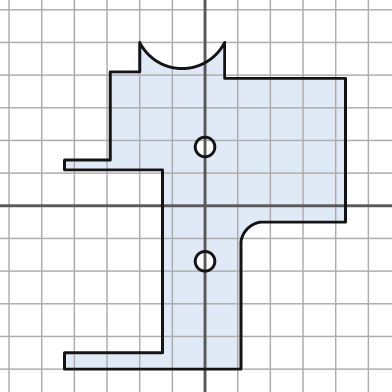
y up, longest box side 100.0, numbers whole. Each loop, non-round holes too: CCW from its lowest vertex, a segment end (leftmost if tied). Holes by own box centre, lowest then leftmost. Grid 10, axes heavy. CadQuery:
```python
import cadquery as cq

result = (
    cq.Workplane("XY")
    .moveTo(-43.0, -50.0)
    .lineTo(11.0, -50.0)
    .lineTo(11.0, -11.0)
    .threePointArc((13.0, -7.0), (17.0, -5.0))
    .lineTo(43.0, -5.0)
    .lineTo(43.0, 39.0)
    .lineTo(6.0, 39.0)
    .lineTo(6.0, 50.0)
    .threePointArc((-7.0, 42.0), (-20.0, 50.0))
    .lineTo(-20.0, 41.0)
    .lineTo(-29.0, 41.0)
    .lineTo(-29.0, 14.0)
    .lineTo(-43.0, 14.0)
    .lineTo(-43.0, 11.0)
    .lineTo(-13.0, 11.0)
    .lineTo(-13.0, -45.0)
    .lineTo(-43.0, -45.0)
    .close()
    .moveTo(0.0, -17.0)
    .circle(3.0)
    .moveTo(0.0, 18.0)
    .circle(3.0)
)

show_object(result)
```